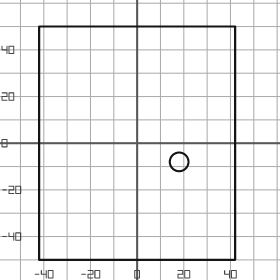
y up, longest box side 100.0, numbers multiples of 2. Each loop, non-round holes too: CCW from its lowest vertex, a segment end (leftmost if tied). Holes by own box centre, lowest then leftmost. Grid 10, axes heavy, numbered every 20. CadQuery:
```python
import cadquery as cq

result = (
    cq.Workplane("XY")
    .moveTo(-42.0, -50.0)
    .lineTo(42.0, -50.0)
    .lineTo(42.0, 50.0)
    .lineTo(-42.0, 50.0)
    .close()
    .moveTo(18.0, -8.0)
    .circle(4.0)
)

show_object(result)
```